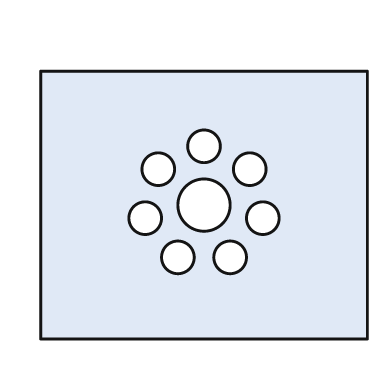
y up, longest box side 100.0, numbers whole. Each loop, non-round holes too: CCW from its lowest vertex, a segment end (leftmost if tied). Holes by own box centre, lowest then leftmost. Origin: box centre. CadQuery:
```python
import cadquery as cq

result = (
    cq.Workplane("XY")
    .moveTo(-50.0, -41.0)
    .lineTo(50.0, -41.0)
    .lineTo(50.0, 41.0)
    .lineTo(-50.0, 41.0)
    .close()
    .moveTo(-8.0, -16.0)
    .circle(5.0)
    .moveTo(8.0, -16.0)
    .circle(5.0)
    .moveTo(-18.0, -4.0)
    .circle(5.0)
    .moveTo(18.0, -4.0)
    .circle(5.0)
    .moveTo(0.0, 0.0)
    .circle(8.0)
    .moveTo(-14.0, 11.0)
    .circle(5.0)
    .moveTo(14.0, 11.0)
    .circle(5.0)
    .moveTo(0.0, 18.0)
    .circle(5.0)
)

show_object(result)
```